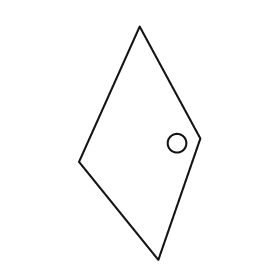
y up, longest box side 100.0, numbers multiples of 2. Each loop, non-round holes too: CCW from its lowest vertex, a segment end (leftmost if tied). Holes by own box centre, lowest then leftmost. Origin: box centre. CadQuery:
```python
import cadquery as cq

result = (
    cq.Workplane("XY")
    .moveTo(8.0, -50.0)
    .lineTo(26.0, 2.0)
    .lineTo(0.0, 50.0)
    .lineTo(-26.0, -8.0)
    .close()
    .moveTo(16.0, 0.0)
    .circle(4.0)
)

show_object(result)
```